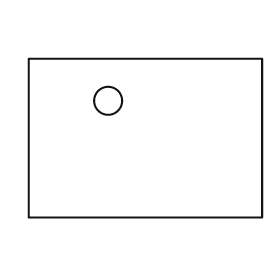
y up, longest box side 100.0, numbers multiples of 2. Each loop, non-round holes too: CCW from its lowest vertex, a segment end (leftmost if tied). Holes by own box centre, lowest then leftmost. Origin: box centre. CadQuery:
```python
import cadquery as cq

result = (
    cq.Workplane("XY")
    .moveTo(-50.0, -34.0)
    .lineTo(50.0, -34.0)
    .lineTo(50.0, 34.0)
    .lineTo(-50.0, 34.0)
    .close()
    .moveTo(-16.0, 16.0)
    .circle(6.0)
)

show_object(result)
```